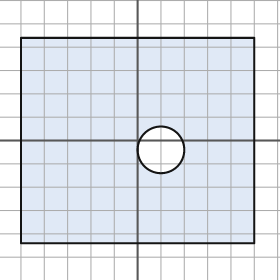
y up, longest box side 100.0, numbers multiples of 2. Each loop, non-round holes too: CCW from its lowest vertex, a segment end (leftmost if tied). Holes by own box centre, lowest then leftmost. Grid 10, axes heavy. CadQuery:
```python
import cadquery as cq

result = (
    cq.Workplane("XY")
    .moveTo(-50.0, -44.0)
    .lineTo(50.0, -44.0)
    .lineTo(50.0, 44.0)
    .lineTo(-50.0, 44.0)
    .close()
    .moveTo(10.0, -4.0)
    .circle(10.0)
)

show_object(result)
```